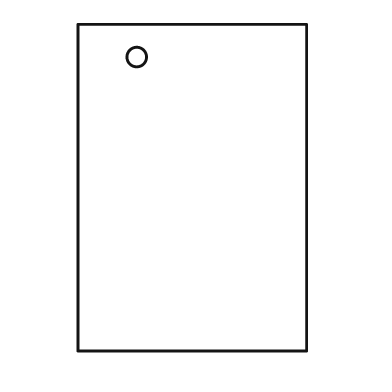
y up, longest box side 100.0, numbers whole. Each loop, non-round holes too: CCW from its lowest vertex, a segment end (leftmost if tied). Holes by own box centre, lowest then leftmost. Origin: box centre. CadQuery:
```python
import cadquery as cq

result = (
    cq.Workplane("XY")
    .moveTo(-35.0, -50.0)
    .lineTo(35.0, -50.0)
    .lineTo(35.0, 50.0)
    .lineTo(-35.0, 50.0)
    .close()
    .moveTo(-17.0, 40.0)
    .circle(3.0)
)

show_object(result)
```